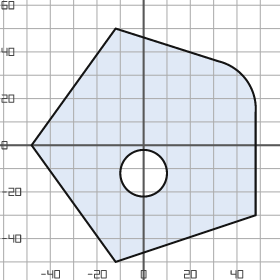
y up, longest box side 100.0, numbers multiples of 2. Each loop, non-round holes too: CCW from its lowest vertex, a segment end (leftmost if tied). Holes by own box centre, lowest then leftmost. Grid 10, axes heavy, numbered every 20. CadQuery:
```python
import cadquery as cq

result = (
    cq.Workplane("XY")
    .moveTo(-12.0, -50.0)
    .lineTo(48.0, -30.0)
    .lineTo(48.0, 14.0)
    .threePointArc((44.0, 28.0), (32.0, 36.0))
    .lineTo(-12.0, 50.0)
    .lineTo(-48.0, 0.0)
    .close()
    .moveTo(0.0, -12.0)
    .circle(10.0)
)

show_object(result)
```